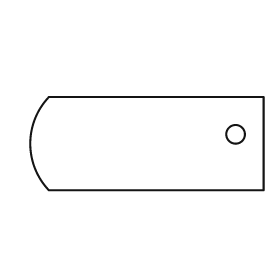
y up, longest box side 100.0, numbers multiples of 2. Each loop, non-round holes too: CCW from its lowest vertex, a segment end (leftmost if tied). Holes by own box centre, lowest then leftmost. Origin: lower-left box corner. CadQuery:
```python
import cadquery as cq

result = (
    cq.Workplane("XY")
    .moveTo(8.0, 0.0)
    .lineTo(100.0, 0.0)
    .lineTo(100.0, 40.0)
    .lineTo(8.0, 40.0)
    .threePointArc((0.0, 20.0), (8.0, 0.0))
    .close()
    .moveTo(88.0, 24.0)
    .circle(4.0)
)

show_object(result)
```